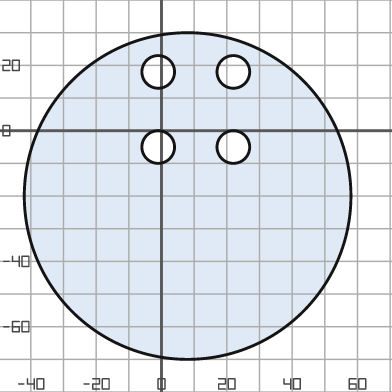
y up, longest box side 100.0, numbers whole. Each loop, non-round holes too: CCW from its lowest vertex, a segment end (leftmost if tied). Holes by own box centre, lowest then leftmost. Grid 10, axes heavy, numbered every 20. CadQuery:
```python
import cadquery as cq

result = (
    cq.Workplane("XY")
    .moveTo(8.0, -20.0)
    .circle(50.0)
    .moveTo(-1.0, -5.0)
    .circle(5.0)
    .moveTo(22.0, -5.0)
    .circle(5.0)
    .moveTo(-1.0, 18.0)
    .circle(5.0)
    .moveTo(22.0, 18.0)
    .circle(5.0)
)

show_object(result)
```